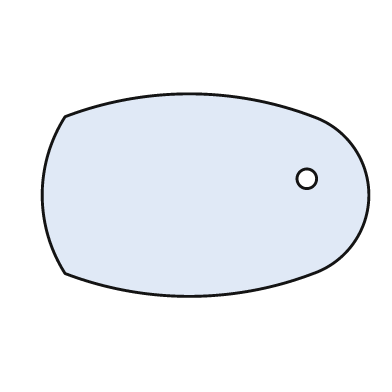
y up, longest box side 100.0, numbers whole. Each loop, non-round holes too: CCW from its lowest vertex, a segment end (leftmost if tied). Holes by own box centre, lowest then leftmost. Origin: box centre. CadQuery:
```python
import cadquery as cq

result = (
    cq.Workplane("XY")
    .moveTo(-43.0, -24.0)
    .threePointArc((-5.0, -31.0), (33.0, -24.0))
    .threePointArc((50.0, 0.0), (33.0, 24.0))
    .threePointArc((-5.0, 31.0), (-43.0, 24.0))
    .threePointArc((-50.0, 0.0), (-43.0, -24.0))
    .close()
    .moveTo(31.0, 5.0)
    .circle(3.0)
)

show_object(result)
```